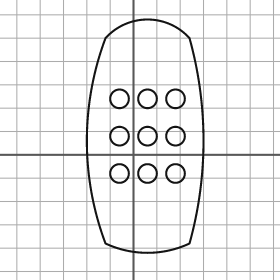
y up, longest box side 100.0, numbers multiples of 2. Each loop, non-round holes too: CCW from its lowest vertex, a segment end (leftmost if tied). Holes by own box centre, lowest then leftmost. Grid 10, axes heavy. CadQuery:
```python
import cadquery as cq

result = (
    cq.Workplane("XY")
    .moveTo(-12.0, -38.0)
    .threePointArc((6.0, -42.0), (24.0, -38.0))
    .threePointArc((30.0, 6.0), (24.0, 50.0))
    .threePointArc((6.0, 58.0), (-12.0, 50.0))
    .threePointArc((-20.0, 6.0), (-12.0, -38.0))
    .close()
    .moveTo(-6.0, -8.0)
    .circle(4.0)
    .moveTo(6.0, -8.0)
    .circle(4.0)
    .moveTo(18.0, -8.0)
    .circle(4.0)
    .moveTo(-6.0, 8.0)
    .circle(4.0)
    .moveTo(6.0, 8.0)
    .circle(4.0)
    .moveTo(18.0, 8.0)
    .circle(4.0)
    .moveTo(-6.0, 24.0)
    .circle(4.0)
    .moveTo(6.0, 24.0)
    .circle(4.0)
    .moveTo(18.0, 24.0)
    .circle(4.0)
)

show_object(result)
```